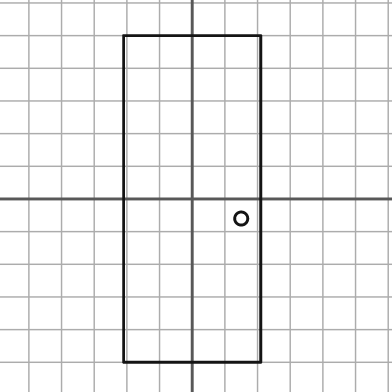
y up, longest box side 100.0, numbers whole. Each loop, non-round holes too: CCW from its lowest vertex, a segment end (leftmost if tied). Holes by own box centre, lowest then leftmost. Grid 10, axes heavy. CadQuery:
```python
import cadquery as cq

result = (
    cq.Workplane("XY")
    .moveTo(-21.0, -50.0)
    .lineTo(21.0, -50.0)
    .lineTo(21.0, 50.0)
    .lineTo(-21.0, 50.0)
    .close()
    .moveTo(15.0, -6.0)
    .circle(2.0)
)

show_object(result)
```